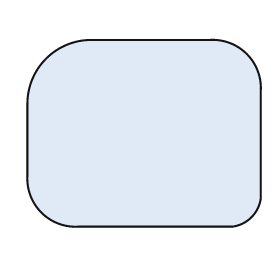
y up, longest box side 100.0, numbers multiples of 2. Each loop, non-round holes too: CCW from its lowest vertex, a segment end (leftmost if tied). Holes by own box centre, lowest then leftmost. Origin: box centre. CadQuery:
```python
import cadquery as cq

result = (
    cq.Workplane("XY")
    .moveTo(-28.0, -40.0)
    .lineTo(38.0, -40.0)
    .threePointArc((46.0, -36.0), (50.0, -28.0))
    .lineTo(50.0, 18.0)
    .threePointArc((44.0, 34.0), (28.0, 40.0))
    .lineTo(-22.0, 40.0)
    .threePointArc((-42.0, 32.0), (-50.0, 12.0))
    .lineTo(-50.0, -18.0)
    .threePointArc((-44.0, -34.0), (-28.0, -40.0))
    .close()
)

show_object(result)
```